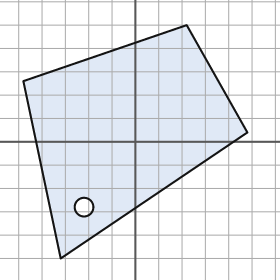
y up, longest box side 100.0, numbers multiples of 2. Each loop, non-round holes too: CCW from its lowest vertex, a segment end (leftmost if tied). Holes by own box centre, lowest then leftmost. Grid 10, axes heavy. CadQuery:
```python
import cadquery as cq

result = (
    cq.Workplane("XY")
    .moveTo(-32.0, -50.0)
    .lineTo(48.0, 4.0)
    .lineTo(22.0, 50.0)
    .lineTo(-48.0, 26.0)
    .close()
    .moveTo(-22.0, -28.0)
    .circle(4.0)
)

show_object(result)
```